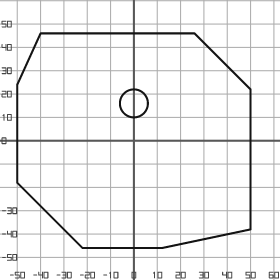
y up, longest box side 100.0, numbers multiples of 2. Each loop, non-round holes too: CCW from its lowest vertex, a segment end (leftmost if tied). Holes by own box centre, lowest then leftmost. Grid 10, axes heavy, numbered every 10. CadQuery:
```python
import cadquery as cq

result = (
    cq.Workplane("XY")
    .moveTo(-22.0, -46.0)
    .lineTo(12.0, -46.0)
    .lineTo(50.0, -38.0)
    .lineTo(50.0, 22.0)
    .lineTo(26.0, 46.0)
    .lineTo(-40.0, 46.0)
    .lineTo(-50.0, 24.0)
    .lineTo(-50.0, -18.0)
    .close()
    .moveTo(0.0, 16.0)
    .circle(6.0)
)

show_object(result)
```